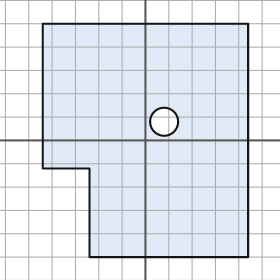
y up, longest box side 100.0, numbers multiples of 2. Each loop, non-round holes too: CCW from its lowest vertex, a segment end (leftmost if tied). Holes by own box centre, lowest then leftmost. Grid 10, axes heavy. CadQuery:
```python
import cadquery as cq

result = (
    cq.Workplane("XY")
    .moveTo(-24.0, -50.0)
    .lineTo(44.0, -50.0)
    .lineTo(44.0, 50.0)
    .lineTo(-44.0, 50.0)
    .lineTo(-44.0, -12.0)
    .lineTo(-24.0, -12.0)
    .close()
    .moveTo(8.0, 8.0)
    .circle(6.0)
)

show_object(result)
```